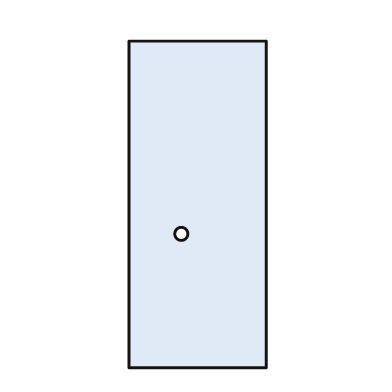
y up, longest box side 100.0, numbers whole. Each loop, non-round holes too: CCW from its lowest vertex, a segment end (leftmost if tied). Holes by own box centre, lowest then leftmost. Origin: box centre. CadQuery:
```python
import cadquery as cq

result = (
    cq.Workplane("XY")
    .moveTo(-21.0, -50.0)
    .lineTo(21.0, -50.0)
    .lineTo(21.0, 50.0)
    .lineTo(-21.0, 50.0)
    .close()
    .moveTo(-5.0, -9.0)
    .circle(2.0)
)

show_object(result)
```